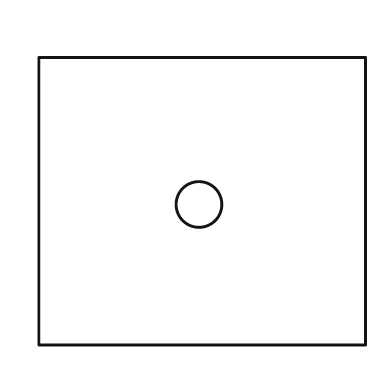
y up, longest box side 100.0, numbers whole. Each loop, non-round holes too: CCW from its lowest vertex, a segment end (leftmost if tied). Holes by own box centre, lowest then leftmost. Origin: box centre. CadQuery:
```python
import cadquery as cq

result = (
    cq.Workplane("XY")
    .moveTo(-50.0, -44.0)
    .lineTo(50.0, -44.0)
    .lineTo(50.0, 44.0)
    .lineTo(-50.0, 44.0)
    .close()
    .moveTo(-1.0, -1.0)
    .circle(7.0)
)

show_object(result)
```